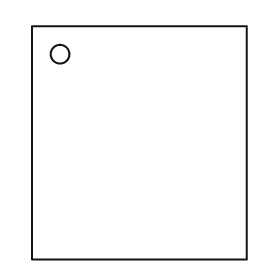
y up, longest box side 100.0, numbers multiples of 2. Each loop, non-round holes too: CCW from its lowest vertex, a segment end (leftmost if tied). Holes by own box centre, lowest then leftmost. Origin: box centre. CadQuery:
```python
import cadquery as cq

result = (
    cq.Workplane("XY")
    .moveTo(-46.0, -50.0)
    .lineTo(46.0, -50.0)
    .lineTo(46.0, 50.0)
    .lineTo(-46.0, 50.0)
    .close()
    .moveTo(-34.0, 38.0)
    .circle(4.0)
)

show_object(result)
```